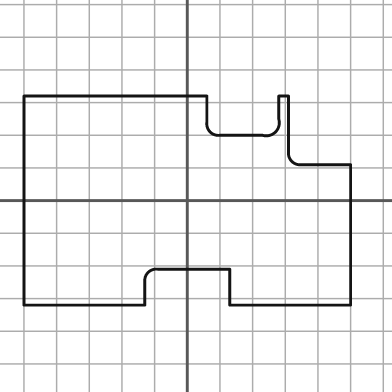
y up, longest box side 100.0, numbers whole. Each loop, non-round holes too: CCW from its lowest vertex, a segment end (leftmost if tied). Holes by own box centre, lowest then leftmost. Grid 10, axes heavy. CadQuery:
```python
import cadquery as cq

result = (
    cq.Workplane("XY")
    .moveTo(-50.0, -32.0)
    .lineTo(-13.0, -32.0)
    .lineTo(-13.0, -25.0)
    .threePointArc((-12.0, -22.0), (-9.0, -21.0))
    .lineTo(13.0, -21.0)
    .lineTo(13.0, -32.0)
    .lineTo(50.0, -32.0)
    .lineTo(50.0, 11.0)
    .lineTo(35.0, 11.0)
    .threePointArc((32.0, 12.0), (31.0, 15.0))
    .lineTo(31.0, 32.0)
    .lineTo(28.0, 32.0)
    .lineTo(28.0, 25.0)
    .threePointArc((27.0, 21.0), (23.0, 20.0))
    .lineTo(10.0, 20.0)
    .threePointArc((7.0, 21.0), (6.0, 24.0))
    .lineTo(6.0, 32.0)
    .lineTo(-50.0, 32.0)
    .close()
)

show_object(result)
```